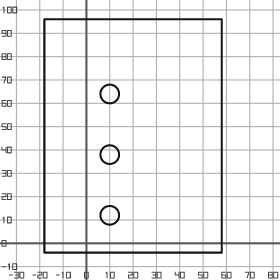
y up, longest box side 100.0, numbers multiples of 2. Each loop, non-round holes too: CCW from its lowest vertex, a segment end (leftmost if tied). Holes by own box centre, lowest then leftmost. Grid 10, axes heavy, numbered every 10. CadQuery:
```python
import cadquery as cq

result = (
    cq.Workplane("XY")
    .moveTo(-18.0, -4.0)
    .lineTo(58.0, -4.0)
    .lineTo(58.0, 96.0)
    .lineTo(-18.0, 96.0)
    .close()
    .moveTo(10.0, 12.0)
    .circle(4.0)
    .moveTo(10.0, 38.0)
    .circle(4.0)
    .moveTo(10.0, 64.0)
    .circle(4.0)
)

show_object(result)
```